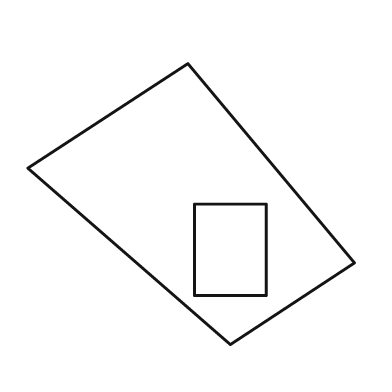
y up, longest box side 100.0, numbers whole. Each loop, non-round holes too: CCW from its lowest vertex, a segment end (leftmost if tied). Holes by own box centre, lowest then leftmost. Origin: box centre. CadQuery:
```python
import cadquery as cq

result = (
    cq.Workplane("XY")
    .moveTo(12.0, -43.0)
    .lineTo(50.0, -18.0)
    .lineTo(-1.0, 43.0)
    .lineTo(-50.0, 11.0)
    .close()
    .moveTo(1.0, -28.0)
    .lineTo(23.0, -28.0)
    .lineTo(23.0, 0.0)
    .lineTo(1.0, 0.0)
    .close()
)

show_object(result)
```